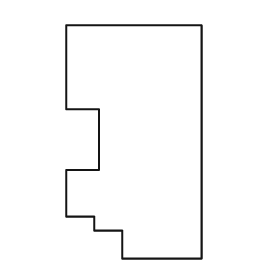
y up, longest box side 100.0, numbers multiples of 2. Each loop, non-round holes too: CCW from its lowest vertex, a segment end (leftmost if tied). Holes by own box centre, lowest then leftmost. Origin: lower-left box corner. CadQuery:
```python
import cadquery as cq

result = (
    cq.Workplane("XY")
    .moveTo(24.0, 0.0)
    .lineTo(58.0, 0.0)
    .lineTo(58.0, 100.0)
    .lineTo(0.0, 100.0)
    .lineTo(0.0, 64.0)
    .lineTo(14.0, 64.0)
    .lineTo(14.0, 38.0)
    .lineTo(0.0, 38.0)
    .lineTo(0.0, 18.0)
    .lineTo(12.0, 18.0)
    .lineTo(12.0, 12.0)
    .lineTo(24.0, 12.0)
    .close()
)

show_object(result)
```